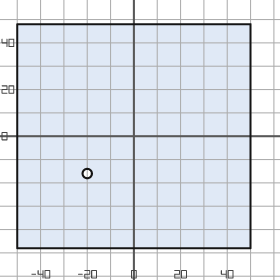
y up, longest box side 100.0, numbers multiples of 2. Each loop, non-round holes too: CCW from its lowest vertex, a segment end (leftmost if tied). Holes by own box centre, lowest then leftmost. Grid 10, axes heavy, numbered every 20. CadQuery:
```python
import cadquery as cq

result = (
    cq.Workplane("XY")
    .moveTo(-50.0, -48.0)
    .lineTo(50.0, -48.0)
    .lineTo(50.0, 48.0)
    .lineTo(-50.0, 48.0)
    .close()
    .moveTo(-20.0, -16.0)
    .circle(2.0)
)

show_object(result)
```